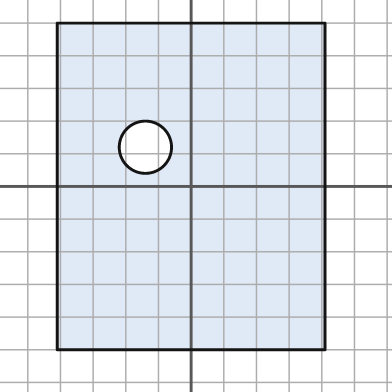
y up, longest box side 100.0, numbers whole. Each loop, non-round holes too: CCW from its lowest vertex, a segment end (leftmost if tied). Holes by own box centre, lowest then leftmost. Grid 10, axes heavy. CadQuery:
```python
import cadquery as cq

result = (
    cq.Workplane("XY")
    .moveTo(-41.0, -50.0)
    .lineTo(41.0, -50.0)
    .lineTo(41.0, 50.0)
    .lineTo(-41.0, 50.0)
    .close()
    .moveTo(-14.0, 12.0)
    .circle(8.0)
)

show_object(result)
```